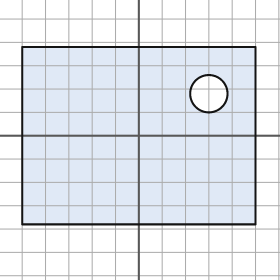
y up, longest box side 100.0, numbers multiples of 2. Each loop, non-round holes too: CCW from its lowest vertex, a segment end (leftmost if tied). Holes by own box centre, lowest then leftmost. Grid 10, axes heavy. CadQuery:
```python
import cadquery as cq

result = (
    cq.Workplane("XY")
    .moveTo(-50.0, -38.0)
    .lineTo(50.0, -38.0)
    .lineTo(50.0, 38.0)
    .lineTo(-50.0, 38.0)
    .close()
    .moveTo(30.0, 18.0)
    .circle(8.0)
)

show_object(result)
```